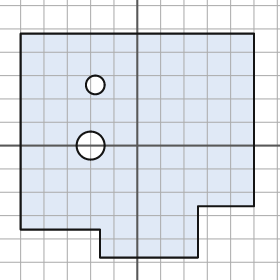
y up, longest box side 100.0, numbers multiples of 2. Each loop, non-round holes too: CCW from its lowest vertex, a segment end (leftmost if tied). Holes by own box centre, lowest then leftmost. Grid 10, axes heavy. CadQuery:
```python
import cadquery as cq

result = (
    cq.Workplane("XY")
    .moveTo(-16.0, -48.0)
    .lineTo(26.0, -48.0)
    .lineTo(26.0, -26.0)
    .lineTo(50.0, -26.0)
    .lineTo(50.0, 48.0)
    .lineTo(-50.0, 48.0)
    .lineTo(-50.0, -36.0)
    .lineTo(-16.0, -36.0)
    .close()
    .moveTo(-20.0, 0.0)
    .circle(6.0)
    .moveTo(-18.0, 26.0)
    .circle(4.0)
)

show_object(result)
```